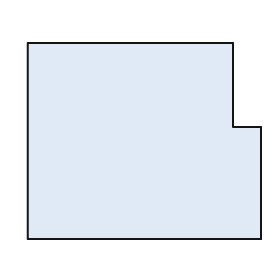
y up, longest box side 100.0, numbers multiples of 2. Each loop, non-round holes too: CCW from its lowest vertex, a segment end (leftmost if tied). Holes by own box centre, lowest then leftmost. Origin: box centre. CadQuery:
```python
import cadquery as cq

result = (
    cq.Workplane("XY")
    .moveTo(-50.0, -42.0)
    .lineTo(50.0, -42.0)
    .lineTo(50.0, 6.0)
    .lineTo(38.0, 6.0)
    .lineTo(38.0, 42.0)
    .lineTo(-50.0, 42.0)
    .close()
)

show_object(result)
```